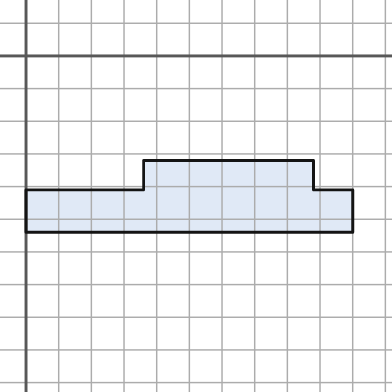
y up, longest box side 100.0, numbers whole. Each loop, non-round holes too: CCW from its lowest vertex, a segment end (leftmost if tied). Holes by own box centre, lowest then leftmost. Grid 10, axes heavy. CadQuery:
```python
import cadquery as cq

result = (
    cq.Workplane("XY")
    .moveTo(0.0, -54.0)
    .lineTo(100.0, -54.0)
    .lineTo(100.0, -41.0)
    .lineTo(88.0, -41.0)
    .lineTo(88.0, -32.0)
    .lineTo(36.0, -32.0)
    .lineTo(36.0, -41.0)
    .lineTo(0.0, -41.0)
    .close()
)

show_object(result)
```